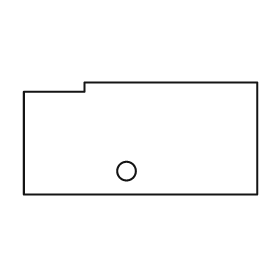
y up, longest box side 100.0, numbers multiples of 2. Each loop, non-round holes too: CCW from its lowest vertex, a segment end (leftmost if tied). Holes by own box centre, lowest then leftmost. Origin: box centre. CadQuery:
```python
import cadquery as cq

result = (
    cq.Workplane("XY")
    .moveTo(-50.0, -24.0)
    .lineTo(50.0, -24.0)
    .lineTo(50.0, 24.0)
    .lineTo(-24.0, 24.0)
    .lineTo(-24.0, 20.0)
    .lineTo(-50.0, 20.0)
    .close()
    .moveTo(-6.0, -14.0)
    .circle(4.0)
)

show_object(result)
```